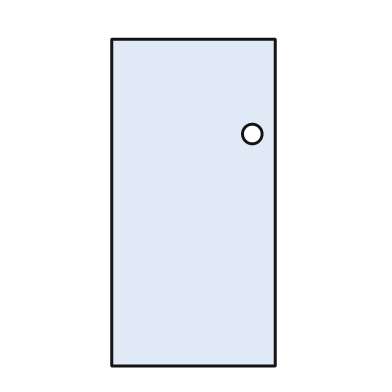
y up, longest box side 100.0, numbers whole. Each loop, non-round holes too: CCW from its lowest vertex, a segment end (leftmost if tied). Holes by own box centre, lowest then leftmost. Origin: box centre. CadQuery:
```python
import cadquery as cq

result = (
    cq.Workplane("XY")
    .moveTo(-25.0, -50.0)
    .lineTo(25.0, -50.0)
    .lineTo(25.0, 50.0)
    .lineTo(-25.0, 50.0)
    .close()
    .moveTo(18.0, 21.0)
    .circle(3.0)
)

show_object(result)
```